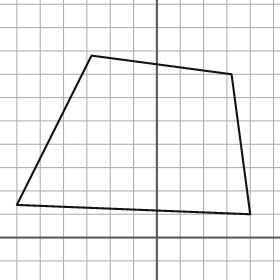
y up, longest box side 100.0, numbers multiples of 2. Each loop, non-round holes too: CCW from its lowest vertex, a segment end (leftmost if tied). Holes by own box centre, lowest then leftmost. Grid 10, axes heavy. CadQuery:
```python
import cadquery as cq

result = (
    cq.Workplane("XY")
    .moveTo(40.0, 10.0)
    .lineTo(32.0, 70.0)
    .lineTo(-28.0, 78.0)
    .lineTo(-60.0, 14.0)
    .close()
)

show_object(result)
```